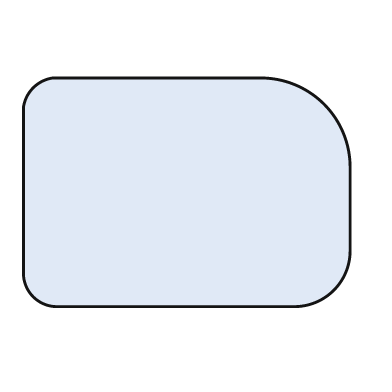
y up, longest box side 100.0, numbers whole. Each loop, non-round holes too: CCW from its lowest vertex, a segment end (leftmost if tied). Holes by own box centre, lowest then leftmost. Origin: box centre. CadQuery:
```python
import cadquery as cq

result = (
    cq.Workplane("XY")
    .moveTo(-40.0, -35.0)
    .lineTo(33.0, -35.0)
    .threePointArc((45.0, -30.0), (50.0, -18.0))
    .lineTo(50.0, 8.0)
    .threePointArc((42.0, 27.0), (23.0, 35.0))
    .lineTo(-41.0, 35.0)
    .threePointArc((-47.0, 32.0), (-50.0, 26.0))
    .lineTo(-50.0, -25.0)
    .threePointArc((-47.0, -32.0), (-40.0, -35.0))
    .close()
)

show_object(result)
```